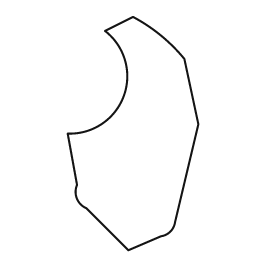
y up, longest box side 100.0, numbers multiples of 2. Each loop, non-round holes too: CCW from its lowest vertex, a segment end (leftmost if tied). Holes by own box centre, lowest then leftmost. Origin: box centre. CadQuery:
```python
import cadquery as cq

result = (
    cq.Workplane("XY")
    .moveTo(-2.0, -50.0)
    .lineTo(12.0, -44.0)
    .threePointArc((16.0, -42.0), (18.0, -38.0))
    .lineTo(28.0, 4.0)
    .lineTo(22.0, 32.0)
    .threePointArc((12.0, 42.0), (0.0, 50.0))
    .lineTo(-12.0, 44.0)
    .threePointArc((-4.0, 16.0), (-28.0, 0.0))
    .lineTo(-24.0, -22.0)
    .threePointArc((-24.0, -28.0), (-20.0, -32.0))
    .close()
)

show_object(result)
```